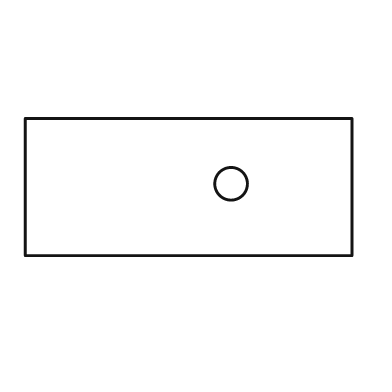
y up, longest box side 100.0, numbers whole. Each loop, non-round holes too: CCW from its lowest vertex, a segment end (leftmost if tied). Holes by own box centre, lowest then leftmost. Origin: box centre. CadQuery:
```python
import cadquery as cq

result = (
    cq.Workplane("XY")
    .moveTo(-50.0, -21.0)
    .lineTo(50.0, -21.0)
    .lineTo(50.0, 21.0)
    .lineTo(-50.0, 21.0)
    .close()
    .moveTo(13.0, 1.0)
    .circle(5.0)
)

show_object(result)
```